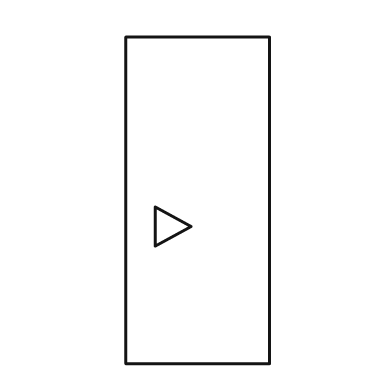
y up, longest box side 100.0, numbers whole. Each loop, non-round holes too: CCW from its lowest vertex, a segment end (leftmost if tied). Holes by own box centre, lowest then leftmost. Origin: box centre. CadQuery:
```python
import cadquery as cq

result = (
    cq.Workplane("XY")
    .moveTo(-22.0, -50.0)
    .lineTo(22.0, -50.0)
    .lineTo(22.0, 50.0)
    .lineTo(-22.0, 50.0)
    .close()
    .moveTo(-13.0, -14.0)
    .lineTo(-2.0, -8.0)
    .lineTo(-13.0, -2.0)
    .close()
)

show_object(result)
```